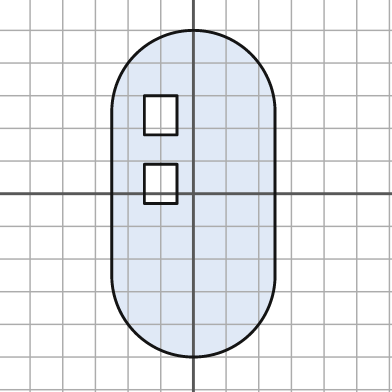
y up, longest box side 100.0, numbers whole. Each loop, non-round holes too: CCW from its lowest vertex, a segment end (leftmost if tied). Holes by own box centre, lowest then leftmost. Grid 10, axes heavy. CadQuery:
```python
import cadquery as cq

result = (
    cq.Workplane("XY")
    .moveTo(-25.0, -25.0)
    .threePointArc((0.0, -50.0), (25.0, -25.0))
    .lineTo(25.0, 25.0)
    .threePointArc((0.0, 50.0), (-25.0, 25.0))
    .close()
    .moveTo(-15.0, -3.0)
    .lineTo(-5.0, -3.0)
    .lineTo(-5.0, 9.0)
    .lineTo(-15.0, 9.0)
    .close()
    .moveTo(-15.0, 18.0)
    .lineTo(-5.0, 18.0)
    .lineTo(-5.0, 30.0)
    .lineTo(-15.0, 30.0)
    .close()
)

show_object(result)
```